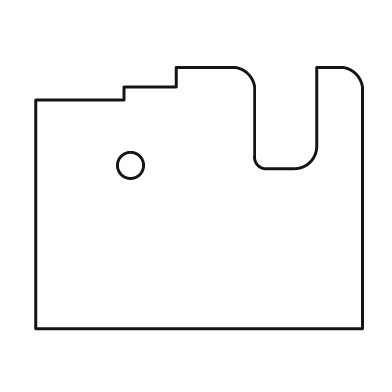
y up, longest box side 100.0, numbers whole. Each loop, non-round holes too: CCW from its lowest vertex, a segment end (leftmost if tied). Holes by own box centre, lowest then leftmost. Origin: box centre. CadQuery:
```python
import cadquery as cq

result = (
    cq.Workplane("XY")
    .moveTo(-50.0, -40.0)
    .lineTo(50.0, -40.0)
    .lineTo(50.0, 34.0)
    .threePointArc((48.0, 38.0), (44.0, 40.0))
    .lineTo(36.0, 40.0)
    .lineTo(36.0, 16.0)
    .threePointArc((34.0, 11.0), (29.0, 9.0))
    .lineTo(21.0, 9.0)
    .threePointArc((18.0, 10.0), (17.0, 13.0))
    .lineTo(17.0, 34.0)
    .threePointArc((15.0, 38.0), (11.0, 40.0))
    .lineTo(-7.0, 40.0)
    .lineTo(-7.0, 34.0)
    .lineTo(-23.0, 34.0)
    .lineTo(-23.0, 30.0)
    .lineTo(-50.0, 30.0)
    .close()
    .moveTo(-21.0, 10.0)
    .circle(4.0)
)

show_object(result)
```